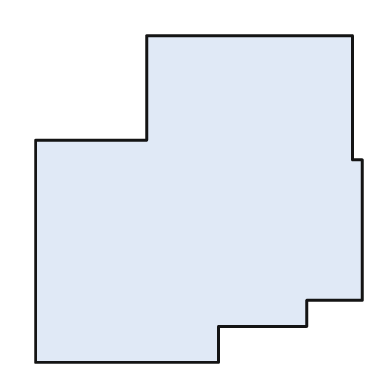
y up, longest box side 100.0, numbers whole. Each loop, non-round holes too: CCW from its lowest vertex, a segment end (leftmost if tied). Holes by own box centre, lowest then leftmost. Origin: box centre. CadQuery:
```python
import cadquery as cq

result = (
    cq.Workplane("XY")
    .moveTo(-50.0, -50.0)
    .lineTo(6.0, -50.0)
    .lineTo(6.0, -39.0)
    .lineTo(33.0, -39.0)
    .lineTo(33.0, -31.0)
    .lineTo(50.0, -31.0)
    .lineTo(50.0, 12.0)
    .lineTo(47.0, 12.0)
    .lineTo(47.0, 50.0)
    .lineTo(-16.0, 50.0)
    .lineTo(-16.0, 18.0)
    .lineTo(-50.0, 18.0)
    .close()
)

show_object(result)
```